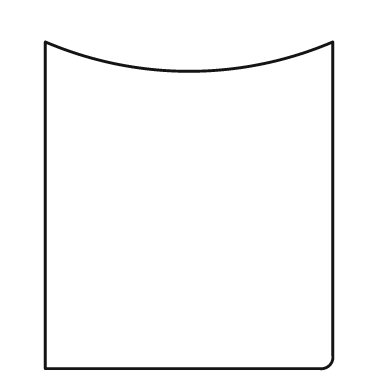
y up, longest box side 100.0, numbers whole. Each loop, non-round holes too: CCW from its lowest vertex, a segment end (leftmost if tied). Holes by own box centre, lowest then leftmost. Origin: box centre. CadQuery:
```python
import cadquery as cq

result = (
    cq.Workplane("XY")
    .moveTo(-44.0, -50.0)
    .lineTo(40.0, -50.0)
    .threePointArc((43.0, -49.0), (44.0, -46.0))
    .lineTo(44.0, 50.0)
    .threePointArc((0.0, 41.0), (-44.0, 50.0))
    .close()
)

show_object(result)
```